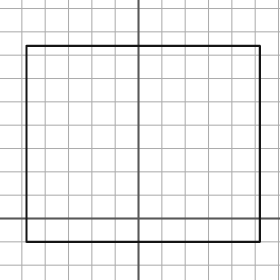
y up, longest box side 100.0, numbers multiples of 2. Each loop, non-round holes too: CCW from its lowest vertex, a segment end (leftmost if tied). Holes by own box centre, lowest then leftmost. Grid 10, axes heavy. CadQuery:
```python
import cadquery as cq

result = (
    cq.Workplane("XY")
    .moveTo(-48.0, -10.0)
    .lineTo(52.0, -10.0)
    .lineTo(52.0, 74.0)
    .lineTo(-48.0, 74.0)
    .close()
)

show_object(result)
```